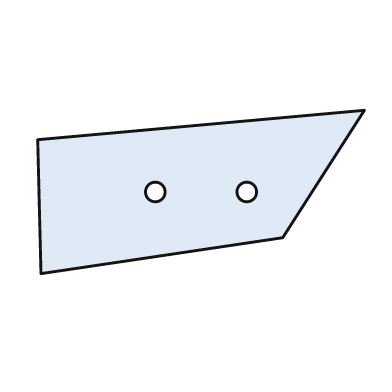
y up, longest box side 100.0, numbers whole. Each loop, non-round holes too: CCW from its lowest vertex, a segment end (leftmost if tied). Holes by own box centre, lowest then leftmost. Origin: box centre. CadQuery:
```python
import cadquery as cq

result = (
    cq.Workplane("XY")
    .moveTo(-49.0, -25.0)
    .lineTo(25.0, -14.0)
    .lineTo(50.0, 25.0)
    .lineTo(-50.0, 16.0)
    .close()
    .moveTo(-14.0, 0.0)
    .circle(3.0)
    .moveTo(14.0, 0.0)
    .circle(3.0)
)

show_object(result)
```